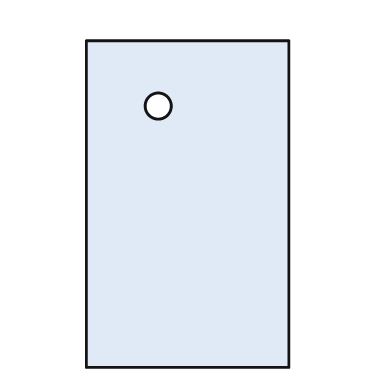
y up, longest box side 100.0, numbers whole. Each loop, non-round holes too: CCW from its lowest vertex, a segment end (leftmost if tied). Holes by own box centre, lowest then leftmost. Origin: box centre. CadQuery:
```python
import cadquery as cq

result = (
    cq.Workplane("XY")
    .moveTo(-31.0, -50.0)
    .lineTo(31.0, -50.0)
    .lineTo(31.0, 50.0)
    .lineTo(-31.0, 50.0)
    .close()
    .moveTo(-9.0, 30.0)
    .circle(4.0)
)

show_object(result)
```